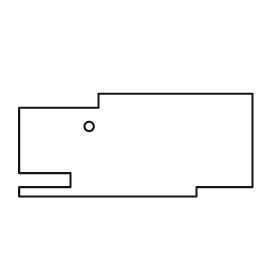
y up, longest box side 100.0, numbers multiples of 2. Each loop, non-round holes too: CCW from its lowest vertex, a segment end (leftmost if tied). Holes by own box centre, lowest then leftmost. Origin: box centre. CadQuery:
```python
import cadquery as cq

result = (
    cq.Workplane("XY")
    .moveTo(-50.0, -22.0)
    .lineTo(26.0, -22.0)
    .lineTo(26.0, -18.0)
    .lineTo(50.0, -18.0)
    .lineTo(50.0, 22.0)
    .lineTo(-16.0, 22.0)
    .lineTo(-16.0, 16.0)
    .lineTo(-50.0, 16.0)
    .lineTo(-50.0, -12.0)
    .lineTo(-28.0, -12.0)
    .lineTo(-28.0, -18.0)
    .lineTo(-50.0, -18.0)
    .close()
    .moveTo(-20.0, 8.0)
    .circle(2.0)
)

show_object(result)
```